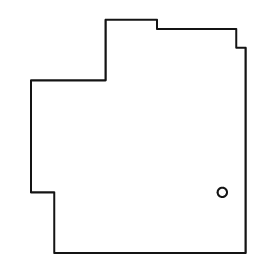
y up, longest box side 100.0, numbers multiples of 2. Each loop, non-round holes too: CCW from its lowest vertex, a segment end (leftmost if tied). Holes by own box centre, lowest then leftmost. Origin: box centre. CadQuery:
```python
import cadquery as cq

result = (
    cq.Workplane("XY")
    .moveTo(-36.0, -50.0)
    .lineTo(46.0, -50.0)
    .lineTo(46.0, 38.0)
    .lineTo(42.0, 38.0)
    .lineTo(42.0, 46.0)
    .lineTo(8.0, 46.0)
    .lineTo(8.0, 50.0)
    .lineTo(-14.0, 50.0)
    .lineTo(-14.0, 24.0)
    .lineTo(-46.0, 24.0)
    .lineTo(-46.0, -24.0)
    .lineTo(-36.0, -24.0)
    .close()
    .moveTo(36.0, -24.0)
    .circle(2.0)
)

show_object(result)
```